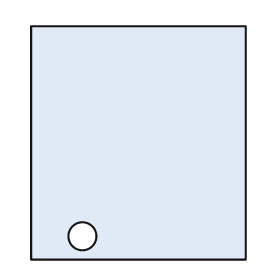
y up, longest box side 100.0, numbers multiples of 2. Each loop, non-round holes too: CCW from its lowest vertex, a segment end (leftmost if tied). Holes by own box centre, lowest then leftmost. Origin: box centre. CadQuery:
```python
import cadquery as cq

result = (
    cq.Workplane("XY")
    .moveTo(-46.0, -50.0)
    .lineTo(46.0, -50.0)
    .lineTo(46.0, 50.0)
    .lineTo(-46.0, 50.0)
    .close()
    .moveTo(-24.0, -40.0)
    .circle(6.0)
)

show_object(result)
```